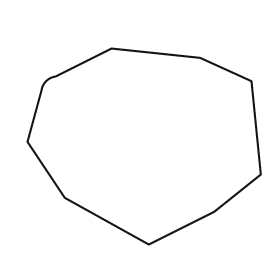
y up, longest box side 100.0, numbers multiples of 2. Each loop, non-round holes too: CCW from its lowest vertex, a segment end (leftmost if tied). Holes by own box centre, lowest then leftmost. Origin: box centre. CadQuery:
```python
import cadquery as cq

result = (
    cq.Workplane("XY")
    .moveTo(2.0, -42.0)
    .lineTo(30.0, -28.0)
    .lineTo(50.0, -12.0)
    .lineTo(46.0, 28.0)
    .lineTo(24.0, 38.0)
    .lineTo(-14.0, 42.0)
    .lineTo(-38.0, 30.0)
    .threePointArc((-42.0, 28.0), (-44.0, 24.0))
    .lineTo(-50.0, 2.0)
    .lineTo(-34.0, -22.0)
    .close()
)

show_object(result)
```